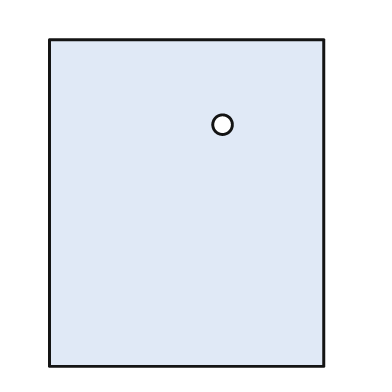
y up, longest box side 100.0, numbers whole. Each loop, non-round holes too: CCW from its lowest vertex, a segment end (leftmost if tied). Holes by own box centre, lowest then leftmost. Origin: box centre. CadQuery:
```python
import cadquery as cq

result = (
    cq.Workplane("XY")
    .moveTo(-42.0, -50.0)
    .lineTo(42.0, -50.0)
    .lineTo(42.0, 50.0)
    .lineTo(-42.0, 50.0)
    .close()
    .moveTo(11.0, 24.0)
    .circle(3.0)
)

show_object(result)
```